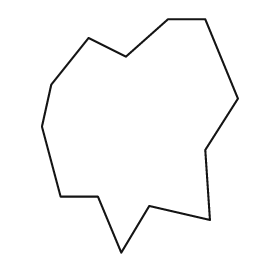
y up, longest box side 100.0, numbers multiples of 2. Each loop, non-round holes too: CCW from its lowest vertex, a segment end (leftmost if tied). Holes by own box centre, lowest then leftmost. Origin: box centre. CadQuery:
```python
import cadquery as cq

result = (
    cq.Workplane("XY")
    .moveTo(-8.0, -50.0)
    .lineTo(4.0, -30.0)
    .lineTo(30.0, -36.0)
    .lineTo(28.0, -6.0)
    .lineTo(42.0, 16.0)
    .lineTo(28.0, 50.0)
    .lineTo(12.0, 50.0)
    .lineTo(-6.0, 34.0)
    .lineTo(-22.0, 42.0)
    .lineTo(-38.0, 22.0)
    .lineTo(-42.0, 4.0)
    .lineTo(-34.0, -26.0)
    .lineTo(-18.0, -26.0)
    .close()
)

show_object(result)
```